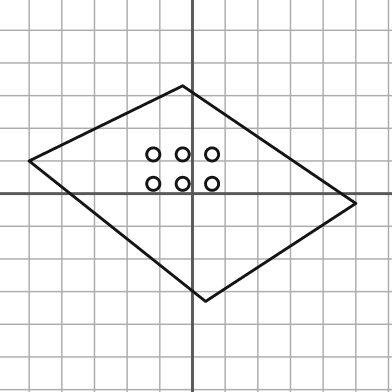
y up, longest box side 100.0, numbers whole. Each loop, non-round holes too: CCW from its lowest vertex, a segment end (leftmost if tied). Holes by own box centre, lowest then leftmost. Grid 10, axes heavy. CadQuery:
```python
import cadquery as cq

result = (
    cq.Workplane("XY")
    .moveTo(4.0, -33.0)
    .lineTo(50.0, -3.0)
    .lineTo(-3.0, 33.0)
    .lineTo(-50.0, 10.0)
    .close()
    .moveTo(-12.0, 3.0)
    .circle(2.0)
    .moveTo(-3.0, 3.0)
    .circle(2.0)
    .moveTo(6.0, 3.0)
    .circle(2.0)
    .moveTo(-12.0, 12.0)
    .circle(2.0)
    .moveTo(-3.0, 12.0)
    .circle(2.0)
    .moveTo(6.0, 12.0)
    .circle(2.0)
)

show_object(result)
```